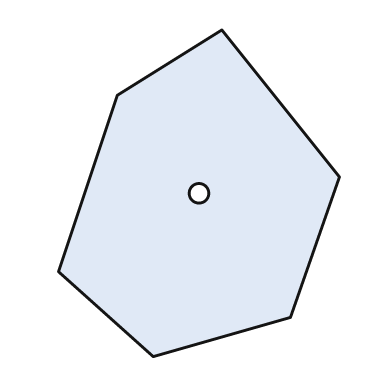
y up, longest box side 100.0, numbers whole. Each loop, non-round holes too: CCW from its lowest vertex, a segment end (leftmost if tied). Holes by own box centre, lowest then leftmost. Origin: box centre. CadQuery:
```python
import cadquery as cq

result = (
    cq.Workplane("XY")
    .moveTo(-14.0, -50.0)
    .lineTo(28.0, -38.0)
    .lineTo(43.0, 5.0)
    .lineTo(7.0, 50.0)
    .lineTo(-25.0, 30.0)
    .lineTo(-43.0, -24.0)
    .close()
    .moveTo(0.0, 0.0)
    .circle(3.0)
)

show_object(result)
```